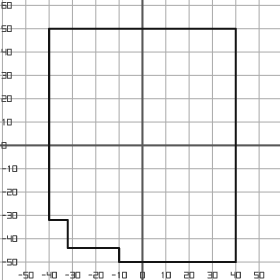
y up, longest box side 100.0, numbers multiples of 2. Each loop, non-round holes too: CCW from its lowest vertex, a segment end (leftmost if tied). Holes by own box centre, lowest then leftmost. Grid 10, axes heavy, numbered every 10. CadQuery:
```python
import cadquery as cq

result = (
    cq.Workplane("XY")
    .moveTo(-10.0, -50.0)
    .lineTo(40.0, -50.0)
    .lineTo(40.0, 50.0)
    .lineTo(-40.0, 50.0)
    .lineTo(-40.0, -32.0)
    .lineTo(-32.0, -32.0)
    .lineTo(-32.0, -44.0)
    .lineTo(-10.0, -44.0)
    .close()
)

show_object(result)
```